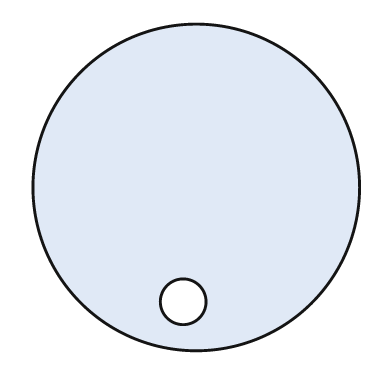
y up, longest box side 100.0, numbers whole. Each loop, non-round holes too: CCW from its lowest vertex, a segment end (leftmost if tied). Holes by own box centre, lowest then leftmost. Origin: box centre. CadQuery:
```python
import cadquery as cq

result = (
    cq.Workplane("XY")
    .moveTo(0.0, 0.0)
    .circle(50.0)
    .moveTo(-4.0, -35.0)
    .circle(7.0)
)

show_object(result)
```